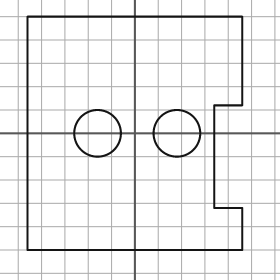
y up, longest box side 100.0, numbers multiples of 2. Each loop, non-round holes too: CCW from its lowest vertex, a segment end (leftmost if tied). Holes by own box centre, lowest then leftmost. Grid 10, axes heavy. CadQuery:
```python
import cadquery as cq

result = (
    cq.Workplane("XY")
    .moveTo(-46.0, -50.0)
    .lineTo(46.0, -50.0)
    .lineTo(46.0, -32.0)
    .lineTo(34.0, -32.0)
    .lineTo(34.0, 12.0)
    .lineTo(46.0, 12.0)
    .lineTo(46.0, 50.0)
    .lineTo(-46.0, 50.0)
    .close()
    .moveTo(-16.0, 0.0)
    .circle(10.0)
    .moveTo(18.0, 0.0)
    .circle(10.0)
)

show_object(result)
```